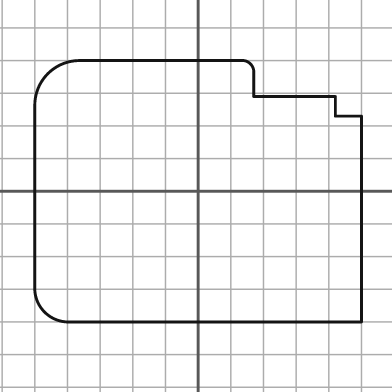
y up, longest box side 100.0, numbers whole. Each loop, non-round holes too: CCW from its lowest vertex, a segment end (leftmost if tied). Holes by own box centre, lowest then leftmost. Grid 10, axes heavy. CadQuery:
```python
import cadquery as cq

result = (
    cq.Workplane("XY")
    .moveTo(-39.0, -40.0)
    .lineTo(50.0, -40.0)
    .lineTo(50.0, 23.0)
    .lineTo(42.0, 23.0)
    .lineTo(42.0, 29.0)
    .lineTo(17.0, 29.0)
    .lineTo(17.0, 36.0)
    .threePointArc((16.0, 39.0), (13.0, 40.0))
    .lineTo(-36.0, 40.0)
    .threePointArc((-46.0, 36.0), (-50.0, 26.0))
    .lineTo(-50.0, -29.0)
    .threePointArc((-47.0, -37.0), (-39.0, -40.0))
    .close()
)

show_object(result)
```